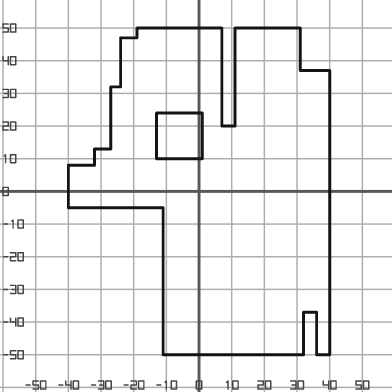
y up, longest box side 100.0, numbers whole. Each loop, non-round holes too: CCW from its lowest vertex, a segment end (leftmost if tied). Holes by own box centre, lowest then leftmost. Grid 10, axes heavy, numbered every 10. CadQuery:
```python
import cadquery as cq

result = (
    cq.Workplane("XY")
    .moveTo(-11.0, -50.0)
    .lineTo(32.0, -50.0)
    .lineTo(32.0, -37.0)
    .lineTo(36.0, -37.0)
    .lineTo(36.0, -50.0)
    .lineTo(40.0, -50.0)
    .lineTo(40.0, 37.0)
    .lineTo(31.0, 37.0)
    .lineTo(31.0, 50.0)
    .lineTo(11.0, 50.0)
    .lineTo(11.0, 20.0)
    .lineTo(7.0, 20.0)
    .lineTo(7.0, 50.0)
    .lineTo(-19.0, 50.0)
    .lineTo(-19.0, 47.0)
    .lineTo(-24.0, 47.0)
    .lineTo(-24.0, 32.0)
    .lineTo(-27.0, 32.0)
    .lineTo(-27.0, 13.0)
    .lineTo(-32.0, 13.0)
    .lineTo(-32.0, 8.0)
    .lineTo(-40.0, 8.0)
    .lineTo(-40.0, -5.0)
    .lineTo(-11.0, -5.0)
    .close()
    .moveTo(-13.0, 10.0)
    .lineTo(1.0, 10.0)
    .lineTo(1.0, 24.0)
    .lineTo(-13.0, 24.0)
    .close()
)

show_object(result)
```